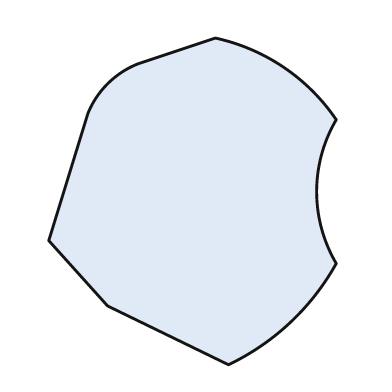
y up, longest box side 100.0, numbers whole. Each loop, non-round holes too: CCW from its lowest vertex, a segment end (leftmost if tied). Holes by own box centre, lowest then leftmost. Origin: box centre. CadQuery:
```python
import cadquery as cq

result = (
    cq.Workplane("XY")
    .moveTo(11.0, -50.0)
    .threePointArc((30.0, -37.0), (44.0, -19.0))
    .threePointArc((38.0, 3.0), (44.0, 25.0))
    .threePointArc((28.0, 41.0), (7.0, 50.0))
    .lineTo(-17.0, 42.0)
    .threePointArc((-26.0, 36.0), (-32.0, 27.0))
    .lineTo(-44.0, -12.0)
    .lineTo(-26.0, -32.0)
    .close()
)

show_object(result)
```